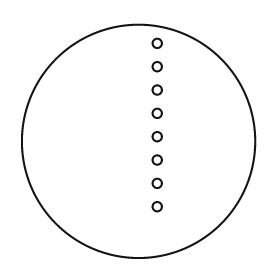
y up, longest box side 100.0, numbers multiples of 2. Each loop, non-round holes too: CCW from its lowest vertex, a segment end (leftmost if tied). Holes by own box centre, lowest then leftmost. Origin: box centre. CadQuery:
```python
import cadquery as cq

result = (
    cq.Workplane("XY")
    .moveTo(0.0, 0.0)
    .circle(50.0)
    .moveTo(8.0, -28.0)
    .circle(2.0)
    .moveTo(8.0, -18.0)
    .circle(2.0)
    .moveTo(8.0, -8.0)
    .circle(2.0)
    .moveTo(8.0, 2.0)
    .circle(2.0)
    .moveTo(8.0, 12.0)
    .circle(2.0)
    .moveTo(8.0, 22.0)
    .circle(2.0)
    .moveTo(8.0, 32.0)
    .circle(2.0)
    .moveTo(8.0, 42.0)
    .circle(2.0)
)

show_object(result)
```